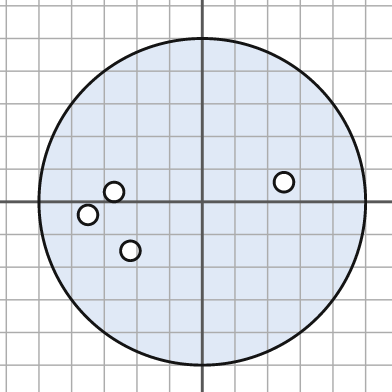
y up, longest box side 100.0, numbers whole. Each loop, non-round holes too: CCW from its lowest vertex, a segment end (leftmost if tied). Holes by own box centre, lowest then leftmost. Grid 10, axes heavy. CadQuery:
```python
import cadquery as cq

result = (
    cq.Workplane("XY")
    .moveTo(0.0, 0.0)
    .circle(50.0)
    .moveTo(-22.0, -15.0)
    .circle(3.0)
    .moveTo(-35.0, -4.0)
    .circle(3.0)
    .moveTo(-27.0, 3.0)
    .circle(3.0)
    .moveTo(25.0, 6.0)
    .circle(3.0)
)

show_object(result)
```